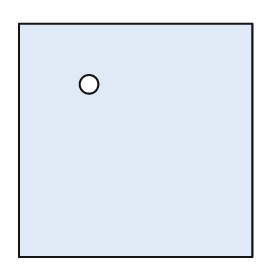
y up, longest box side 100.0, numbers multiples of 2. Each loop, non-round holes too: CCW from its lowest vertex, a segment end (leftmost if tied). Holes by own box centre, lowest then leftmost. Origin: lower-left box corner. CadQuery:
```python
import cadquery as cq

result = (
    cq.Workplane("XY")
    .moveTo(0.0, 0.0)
    .lineTo(100.0, 0.0)
    .lineTo(100.0, 100.0)
    .lineTo(0.0, 100.0)
    .close()
    .moveTo(30.0, 74.0)
    .circle(4.0)
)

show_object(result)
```